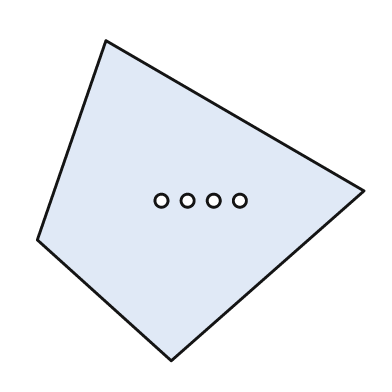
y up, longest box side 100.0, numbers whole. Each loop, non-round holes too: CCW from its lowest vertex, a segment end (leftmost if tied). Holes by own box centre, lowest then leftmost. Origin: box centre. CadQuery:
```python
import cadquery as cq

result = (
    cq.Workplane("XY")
    .moveTo(-9.0, -49.0)
    .lineTo(50.0, 3.0)
    .lineTo(-29.0, 49.0)
    .lineTo(-50.0, -12.0)
    .close()
    .moveTo(-12.0, 0.0)
    .circle(2.0)
    .moveTo(-4.0, 0.0)
    .circle(2.0)
    .moveTo(4.0, 0.0)
    .circle(2.0)
    .moveTo(12.0, 0.0)
    .circle(2.0)
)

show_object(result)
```